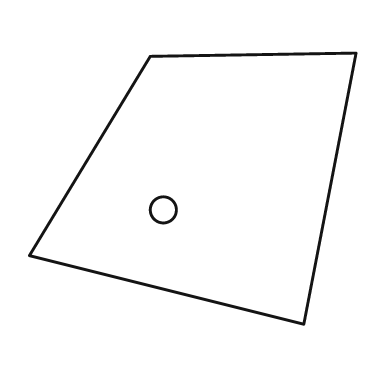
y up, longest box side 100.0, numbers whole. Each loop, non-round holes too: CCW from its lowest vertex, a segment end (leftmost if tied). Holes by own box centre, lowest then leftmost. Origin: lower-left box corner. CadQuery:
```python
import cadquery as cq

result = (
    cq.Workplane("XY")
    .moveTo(84.0, 0.0)
    .lineTo(100.0, 83.0)
    .lineTo(37.0, 82.0)
    .lineTo(0.0, 21.0)
    .close()
    .moveTo(41.0, 35.0)
    .circle(4.0)
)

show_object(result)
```